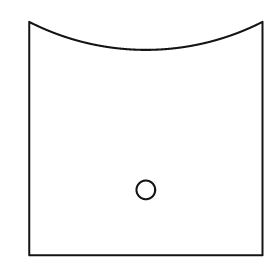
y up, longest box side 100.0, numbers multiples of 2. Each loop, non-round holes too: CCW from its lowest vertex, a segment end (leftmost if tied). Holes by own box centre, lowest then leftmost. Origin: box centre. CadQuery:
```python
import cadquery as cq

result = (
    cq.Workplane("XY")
    .moveTo(-50.0, -50.0)
    .lineTo(50.0, -50.0)
    .lineTo(50.0, 50.0)
    .threePointArc((0.0, 38.0), (-50.0, 50.0))
    .close()
    .moveTo(0.0, -22.0)
    .circle(4.0)
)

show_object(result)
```